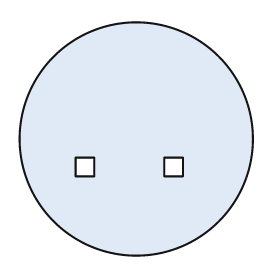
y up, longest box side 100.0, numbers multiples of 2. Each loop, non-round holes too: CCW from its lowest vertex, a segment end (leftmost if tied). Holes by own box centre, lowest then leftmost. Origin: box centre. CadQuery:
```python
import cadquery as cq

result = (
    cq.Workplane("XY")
    .moveTo(0.0, 0.0)
    .circle(50.0)
    .moveTo(-26.0, -16.0)
    .lineTo(-18.0, -16.0)
    .lineTo(-18.0, -8.0)
    .lineTo(-26.0, -8.0)
    .close()
    .moveTo(12.0, -16.0)
    .lineTo(20.0, -16.0)
    .lineTo(20.0, -8.0)
    .lineTo(12.0, -8.0)
    .close()
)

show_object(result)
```